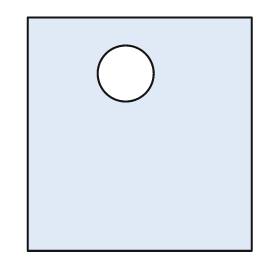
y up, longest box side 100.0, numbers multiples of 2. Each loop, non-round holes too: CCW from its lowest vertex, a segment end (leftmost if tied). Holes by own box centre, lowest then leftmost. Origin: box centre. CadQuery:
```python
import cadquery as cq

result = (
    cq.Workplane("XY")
    .moveTo(-48.0, -50.0)
    .lineTo(48.0, -50.0)
    .lineTo(48.0, 50.0)
    .lineTo(-48.0, 50.0)
    .close()
    .moveTo(-6.0, 26.0)
    .circle(12.0)
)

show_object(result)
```